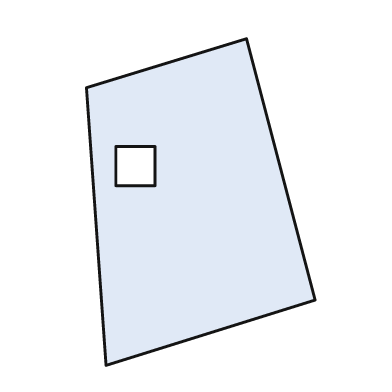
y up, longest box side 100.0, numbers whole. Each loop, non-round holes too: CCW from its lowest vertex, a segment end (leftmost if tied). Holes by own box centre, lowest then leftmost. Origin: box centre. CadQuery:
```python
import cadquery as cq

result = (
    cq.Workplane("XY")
    .moveTo(-29.0, -50.0)
    .lineTo(35.0, -30.0)
    .lineTo(14.0, 50.0)
    .lineTo(-35.0, 35.0)
    .close()
    .moveTo(-26.0, 5.0)
    .lineTo(-14.0, 5.0)
    .lineTo(-14.0, 17.0)
    .lineTo(-26.0, 17.0)
    .close()
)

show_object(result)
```